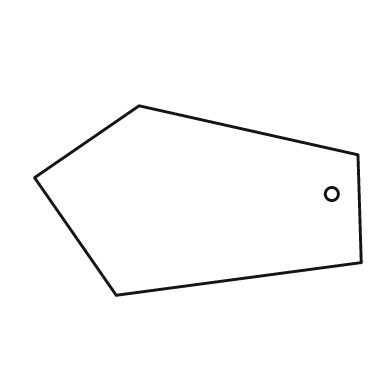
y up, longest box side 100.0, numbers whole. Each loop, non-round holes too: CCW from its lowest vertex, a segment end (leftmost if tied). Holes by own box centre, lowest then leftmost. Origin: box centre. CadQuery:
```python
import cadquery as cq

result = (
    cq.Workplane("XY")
    .moveTo(-25.0, -29.0)
    .lineTo(50.0, -19.0)
    .lineTo(49.0, 14.0)
    .lineTo(-18.0, 29.0)
    .lineTo(-50.0, 7.0)
    .close()
    .moveTo(41.0, 2.0)
    .circle(2.0)
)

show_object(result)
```